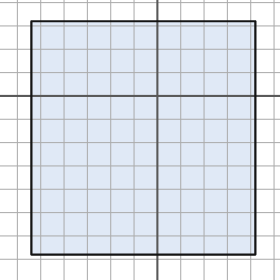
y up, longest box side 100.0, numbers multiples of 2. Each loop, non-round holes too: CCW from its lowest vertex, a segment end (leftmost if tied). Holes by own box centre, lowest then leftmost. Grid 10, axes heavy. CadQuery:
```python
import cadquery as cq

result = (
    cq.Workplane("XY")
    .moveTo(-54.0, -68.0)
    .lineTo(42.0, -68.0)
    .lineTo(42.0, 32.0)
    .lineTo(-54.0, 32.0)
    .close()
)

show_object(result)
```